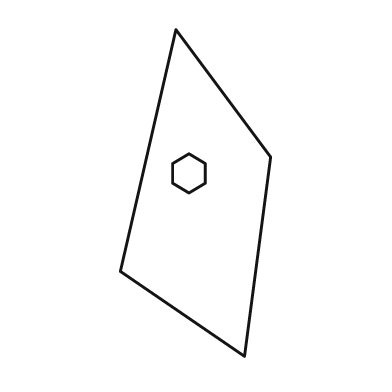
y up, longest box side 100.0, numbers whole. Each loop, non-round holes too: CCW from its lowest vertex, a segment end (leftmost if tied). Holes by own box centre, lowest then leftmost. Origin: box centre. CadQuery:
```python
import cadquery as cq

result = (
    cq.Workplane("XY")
    .moveTo(15.0, -50.0)
    .lineTo(23.0, 11.0)
    .lineTo(-6.0, 50.0)
    .lineTo(-23.0, -24.0)
    .close()
    .moveTo(-2.0, 0.0)
    .lineTo(3.0, 3.0)
    .lineTo(3.0, 9.0)
    .lineTo(-2.0, 12.0)
    .lineTo(-7.0, 9.0)
    .lineTo(-7.0, 3.0)
    .close()
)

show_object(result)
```